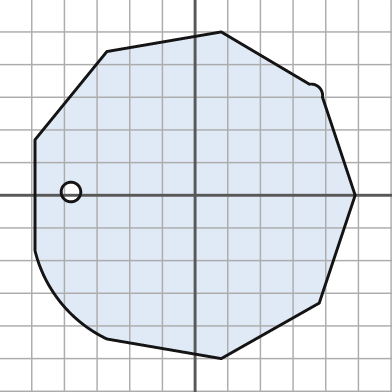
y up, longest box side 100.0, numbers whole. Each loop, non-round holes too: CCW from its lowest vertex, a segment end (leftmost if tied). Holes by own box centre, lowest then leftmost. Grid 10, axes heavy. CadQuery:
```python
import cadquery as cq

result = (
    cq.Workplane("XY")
    .moveTo(8.0, -50.0)
    .lineTo(38.0, -33.0)
    .lineTo(49.0, 0.0)
    .lineTo(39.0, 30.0)
    .threePointArc((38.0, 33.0), (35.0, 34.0))
    .lineTo(8.0, 50.0)
    .lineTo(-27.0, 44.0)
    .lineTo(-49.0, 17.0)
    .lineTo(-49.0, -17.0)
    .threePointArc((-41.0, -33.0), (-27.0, -44.0))
    .close()
    .moveTo(-38.0, 1.0)
    .circle(3.0)
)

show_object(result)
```